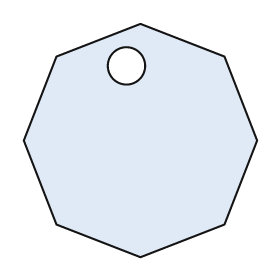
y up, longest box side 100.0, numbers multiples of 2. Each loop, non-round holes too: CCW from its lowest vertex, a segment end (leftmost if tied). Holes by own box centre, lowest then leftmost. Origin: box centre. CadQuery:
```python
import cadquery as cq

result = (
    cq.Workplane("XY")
    .moveTo(0.0, -50.0)
    .lineTo(36.0, -36.0)
    .lineTo(50.0, 0.0)
    .lineTo(36.0, 36.0)
    .lineTo(0.0, 50.0)
    .lineTo(-36.0, 36.0)
    .lineTo(-50.0, 0.0)
    .lineTo(-36.0, -36.0)
    .close()
    .moveTo(-6.0, 32.0)
    .circle(8.0)
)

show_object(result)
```